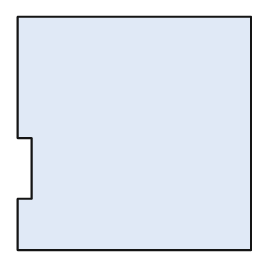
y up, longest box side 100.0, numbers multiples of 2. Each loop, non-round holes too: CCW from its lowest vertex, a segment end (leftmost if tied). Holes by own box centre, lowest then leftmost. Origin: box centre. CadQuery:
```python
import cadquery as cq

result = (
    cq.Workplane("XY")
    .moveTo(-50.0, -50.0)
    .lineTo(50.0, -50.0)
    .lineTo(50.0, 50.0)
    .lineTo(-50.0, 50.0)
    .lineTo(-50.0, -2.0)
    .lineTo(-44.0, -2.0)
    .lineTo(-44.0, -28.0)
    .lineTo(-50.0, -28.0)
    .close()
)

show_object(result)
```